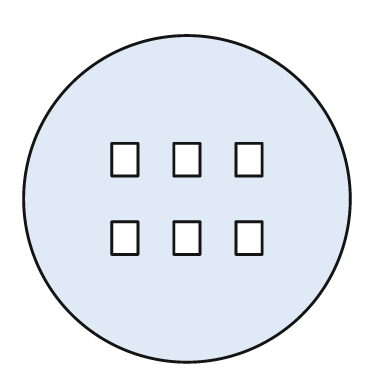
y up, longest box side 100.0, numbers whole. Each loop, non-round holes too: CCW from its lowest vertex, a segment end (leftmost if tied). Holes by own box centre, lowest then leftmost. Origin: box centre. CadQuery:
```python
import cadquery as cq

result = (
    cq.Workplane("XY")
    .moveTo(0.0, 0.0)
    .circle(50.0)
    .moveTo(-23.0, -17.0)
    .lineTo(-15.0, -17.0)
    .lineTo(-15.0, -7.0)
    .lineTo(-23.0, -7.0)
    .close()
    .moveTo(-4.0, -17.0)
    .lineTo(4.0, -17.0)
    .lineTo(4.0, -7.0)
    .lineTo(-4.0, -7.0)
    .close()
    .moveTo(15.0, -17.0)
    .lineTo(23.0, -17.0)
    .lineTo(23.0, -7.0)
    .lineTo(15.0, -7.0)
    .close()
    .moveTo(-23.0, 7.0)
    .lineTo(-15.0, 7.0)
    .lineTo(-15.0, 17.0)
    .lineTo(-23.0, 17.0)
    .close()
    .moveTo(-4.0, 7.0)
    .lineTo(4.0, 7.0)
    .lineTo(4.0, 17.0)
    .lineTo(-4.0, 17.0)
    .close()
    .moveTo(15.0, 7.0)
    .lineTo(23.0, 7.0)
    .lineTo(23.0, 17.0)
    .lineTo(15.0, 17.0)
    .close()
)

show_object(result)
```